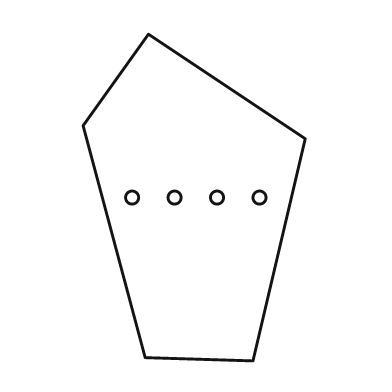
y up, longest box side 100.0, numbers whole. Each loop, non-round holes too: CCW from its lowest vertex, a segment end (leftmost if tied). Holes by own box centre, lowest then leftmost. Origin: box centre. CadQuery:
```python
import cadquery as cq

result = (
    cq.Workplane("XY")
    .moveTo(18.0, -50.0)
    .lineTo(34.0, 18.0)
    .lineTo(-14.0, 50.0)
    .lineTo(-34.0, 22.0)
    .lineTo(-15.0, -49.0)
    .close()
    .moveTo(-19.0, 0.0)
    .circle(2.0)
    .moveTo(-6.0, 0.0)
    .circle(2.0)
    .moveTo(7.0, 0.0)
    .circle(2.0)
    .moveTo(20.0, 0.0)
    .circle(2.0)
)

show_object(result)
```